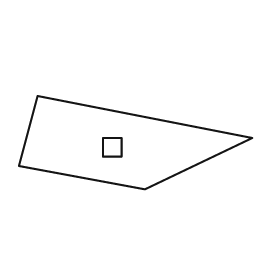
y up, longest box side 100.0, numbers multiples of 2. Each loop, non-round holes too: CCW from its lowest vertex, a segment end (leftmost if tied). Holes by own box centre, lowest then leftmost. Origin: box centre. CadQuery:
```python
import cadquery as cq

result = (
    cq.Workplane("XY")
    .moveTo(4.0, -20.0)
    .lineTo(50.0, 2.0)
    .lineTo(-42.0, 20.0)
    .lineTo(-50.0, -10.0)
    .close()
    .moveTo(-14.0, -6.0)
    .lineTo(-6.0, -6.0)
    .lineTo(-6.0, 2.0)
    .lineTo(-14.0, 2.0)
    .close()
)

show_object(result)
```